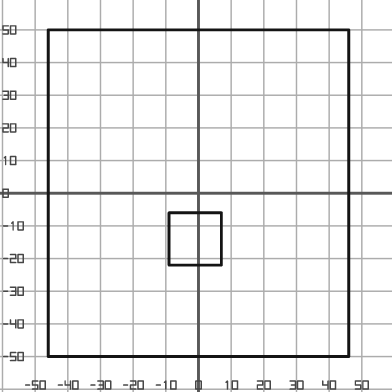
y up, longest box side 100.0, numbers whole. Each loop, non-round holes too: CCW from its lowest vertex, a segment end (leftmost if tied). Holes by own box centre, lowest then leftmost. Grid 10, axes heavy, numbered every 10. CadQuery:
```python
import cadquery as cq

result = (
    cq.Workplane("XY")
    .moveTo(-46.0, -50.0)
    .lineTo(46.0, -50.0)
    .lineTo(46.0, 50.0)
    .lineTo(-46.0, 50.0)
    .close()
    .moveTo(-9.0, -22.0)
    .lineTo(7.0, -22.0)
    .lineTo(7.0, -6.0)
    .lineTo(-9.0, -6.0)
    .close()
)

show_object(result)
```